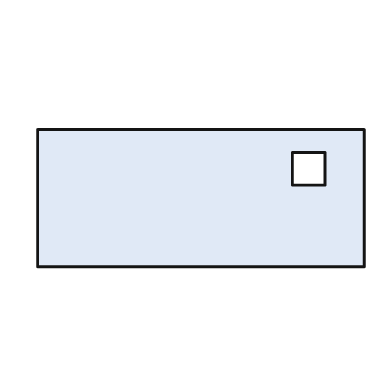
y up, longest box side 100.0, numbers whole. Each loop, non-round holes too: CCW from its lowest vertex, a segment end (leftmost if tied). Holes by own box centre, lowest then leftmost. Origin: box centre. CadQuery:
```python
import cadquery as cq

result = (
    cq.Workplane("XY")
    .moveTo(-50.0, -21.0)
    .lineTo(50.0, -21.0)
    .lineTo(50.0, 21.0)
    .lineTo(-50.0, 21.0)
    .close()
    .moveTo(28.0, 4.0)
    .lineTo(38.0, 4.0)
    .lineTo(38.0, 14.0)
    .lineTo(28.0, 14.0)
    .close()
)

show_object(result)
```